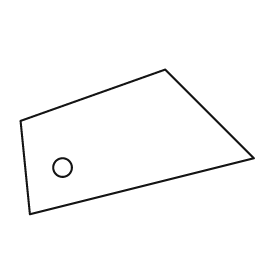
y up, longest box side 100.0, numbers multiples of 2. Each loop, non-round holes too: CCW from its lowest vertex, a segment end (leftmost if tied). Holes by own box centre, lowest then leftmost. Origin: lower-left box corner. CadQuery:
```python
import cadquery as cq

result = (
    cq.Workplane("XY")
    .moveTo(4.0, 0.0)
    .lineTo(100.0, 24.0)
    .lineTo(62.0, 62.0)
    .lineTo(0.0, 40.0)
    .close()
    .moveTo(18.0, 20.0)
    .circle(4.0)
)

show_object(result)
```